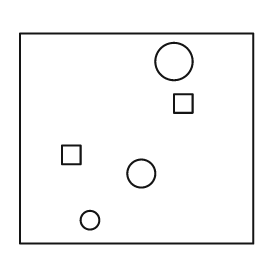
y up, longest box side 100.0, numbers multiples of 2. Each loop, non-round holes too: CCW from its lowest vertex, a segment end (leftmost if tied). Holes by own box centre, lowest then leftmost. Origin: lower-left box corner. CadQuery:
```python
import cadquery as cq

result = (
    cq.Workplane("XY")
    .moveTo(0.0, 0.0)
    .lineTo(100.0, 0.0)
    .lineTo(100.0, 90.0)
    .lineTo(0.0, 90.0)
    .close()
    .moveTo(30.0, 10.0)
    .circle(4.0)
    .moveTo(52.0, 30.0)
    .circle(6.0)
    .moveTo(18.0, 34.0)
    .lineTo(26.0, 34.0)
    .lineTo(26.0, 42.0)
    .lineTo(18.0, 42.0)
    .close()
    .moveTo(66.0, 56.0)
    .lineTo(74.0, 56.0)
    .lineTo(74.0, 64.0)
    .lineTo(66.0, 64.0)
    .close()
    .moveTo(66.0, 78.0)
    .circle(8.0)
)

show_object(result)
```